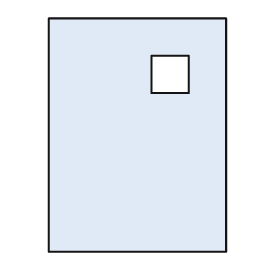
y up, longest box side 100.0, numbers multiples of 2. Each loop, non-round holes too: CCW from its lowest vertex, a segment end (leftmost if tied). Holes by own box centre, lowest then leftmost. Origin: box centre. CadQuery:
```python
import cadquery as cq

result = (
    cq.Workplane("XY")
    .moveTo(-38.0, -50.0)
    .lineTo(38.0, -50.0)
    .lineTo(38.0, 50.0)
    .lineTo(-38.0, 50.0)
    .close()
    .moveTo(6.0, 18.0)
    .lineTo(22.0, 18.0)
    .lineTo(22.0, 34.0)
    .lineTo(6.0, 34.0)
    .close()
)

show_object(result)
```